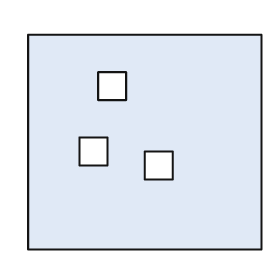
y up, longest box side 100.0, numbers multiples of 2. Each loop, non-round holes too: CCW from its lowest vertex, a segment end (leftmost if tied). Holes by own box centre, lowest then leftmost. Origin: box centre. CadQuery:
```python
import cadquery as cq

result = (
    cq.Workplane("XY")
    .moveTo(-50.0, -46.0)
    .lineTo(50.0, -46.0)
    .lineTo(50.0, 46.0)
    .lineTo(-50.0, 46.0)
    .close()
    .moveTo(0.0, -16.0)
    .lineTo(12.0, -16.0)
    .lineTo(12.0, -4.0)
    .lineTo(0.0, -4.0)
    .close()
    .moveTo(-28.0, -10.0)
    .lineTo(-16.0, -10.0)
    .lineTo(-16.0, 2.0)
    .lineTo(-28.0, 2.0)
    .close()
    .moveTo(-20.0, 18.0)
    .lineTo(-8.0, 18.0)
    .lineTo(-8.0, 30.0)
    .lineTo(-20.0, 30.0)
    .close()
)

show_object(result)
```